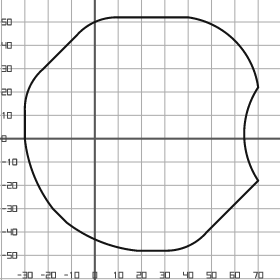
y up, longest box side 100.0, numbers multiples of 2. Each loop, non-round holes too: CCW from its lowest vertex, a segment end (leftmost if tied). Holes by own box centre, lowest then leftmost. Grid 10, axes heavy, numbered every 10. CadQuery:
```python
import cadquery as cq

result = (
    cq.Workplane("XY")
    .moveTo(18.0, -48.0)
    .lineTo(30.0, -48.0)
    .threePointArc((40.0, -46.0), (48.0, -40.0))
    .lineTo(70.0, -18.0)
    .threePointArc((64.0, 2.0), (70.0, 22.0))
    .threePointArc((60.0, 42.0), (40.0, 52.0))
    .lineTo(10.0, 52.0)
    .threePointArc((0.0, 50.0), (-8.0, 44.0))
    .lineTo(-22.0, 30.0)
    .threePointArc((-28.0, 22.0), (-30.0, 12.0))
    .lineTo(-30.0, 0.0)
    .threePointArc((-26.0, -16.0), (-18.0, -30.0))
    .lineTo(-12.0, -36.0)
    .threePointArc((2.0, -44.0), (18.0, -48.0))
    .close()
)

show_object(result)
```